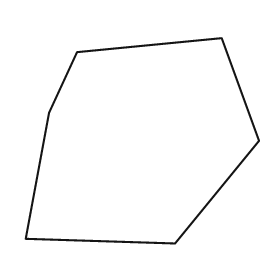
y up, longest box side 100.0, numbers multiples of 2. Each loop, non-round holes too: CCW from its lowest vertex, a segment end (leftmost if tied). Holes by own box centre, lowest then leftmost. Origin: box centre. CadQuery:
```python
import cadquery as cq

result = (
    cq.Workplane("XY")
    .moveTo(14.0, -44.0)
    .lineTo(50.0, 0.0)
    .lineTo(34.0, 44.0)
    .lineTo(-28.0, 38.0)
    .lineTo(-40.0, 12.0)
    .lineTo(-50.0, -42.0)
    .close()
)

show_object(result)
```